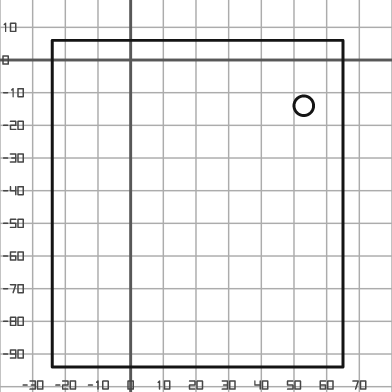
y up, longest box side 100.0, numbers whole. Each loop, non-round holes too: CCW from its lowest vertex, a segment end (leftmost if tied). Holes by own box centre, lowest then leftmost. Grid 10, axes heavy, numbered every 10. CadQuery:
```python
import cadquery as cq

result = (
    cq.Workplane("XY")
    .moveTo(-24.0, -94.0)
    .lineTo(65.0, -94.0)
    .lineTo(65.0, 6.0)
    .lineTo(-24.0, 6.0)
    .close()
    .moveTo(53.0, -14.0)
    .circle(3.0)
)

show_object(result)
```